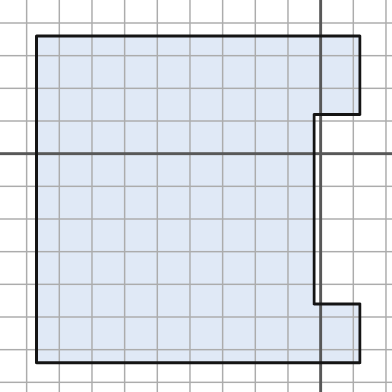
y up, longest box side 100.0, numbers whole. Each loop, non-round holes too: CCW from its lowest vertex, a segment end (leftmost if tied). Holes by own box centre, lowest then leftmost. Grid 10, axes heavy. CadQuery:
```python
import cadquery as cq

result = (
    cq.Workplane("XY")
    .moveTo(-87.0, -64.0)
    .lineTo(12.0, -64.0)
    .lineTo(12.0, -46.0)
    .lineTo(-2.0, -46.0)
    .lineTo(-2.0, 12.0)
    .lineTo(12.0, 12.0)
    .lineTo(12.0, 36.0)
    .lineTo(-87.0, 36.0)
    .close()
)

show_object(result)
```